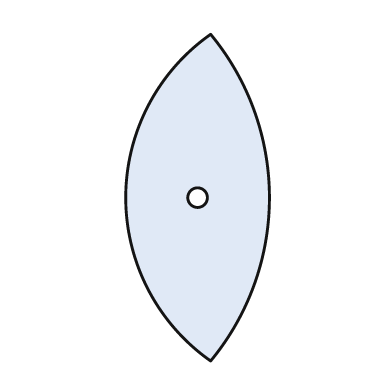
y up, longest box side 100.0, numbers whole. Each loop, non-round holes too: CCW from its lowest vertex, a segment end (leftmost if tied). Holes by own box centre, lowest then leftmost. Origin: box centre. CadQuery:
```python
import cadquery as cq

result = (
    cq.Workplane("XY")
    .moveTo(4.0, -50.0)
    .threePointArc((22.0, 0.0), (4.0, 50.0))
    .threePointArc((-22.0, 0.0), (4.0, -50.0))
    .close()
    .moveTo(0.0, 0.0)
    .circle(3.0)
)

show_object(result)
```